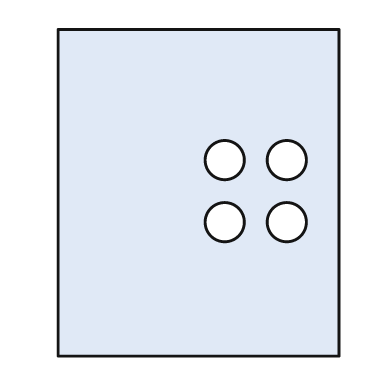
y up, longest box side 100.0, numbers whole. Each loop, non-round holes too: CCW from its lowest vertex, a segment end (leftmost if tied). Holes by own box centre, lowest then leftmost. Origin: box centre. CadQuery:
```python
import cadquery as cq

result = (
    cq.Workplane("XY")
    .moveTo(-43.0, -50.0)
    .lineTo(43.0, -50.0)
    .lineTo(43.0, 50.0)
    .lineTo(-43.0, 50.0)
    .close()
    .moveTo(8.0, -9.0)
    .circle(6.0)
    .moveTo(27.0, -9.0)
    .circle(6.0)
    .moveTo(8.0, 10.0)
    .circle(6.0)
    .moveTo(27.0, 10.0)
    .circle(6.0)
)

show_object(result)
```